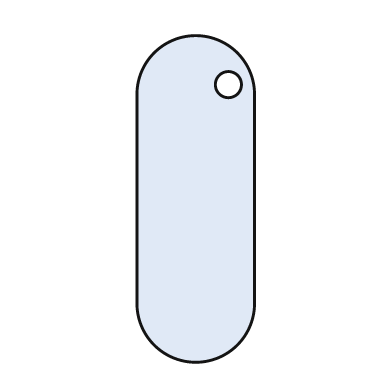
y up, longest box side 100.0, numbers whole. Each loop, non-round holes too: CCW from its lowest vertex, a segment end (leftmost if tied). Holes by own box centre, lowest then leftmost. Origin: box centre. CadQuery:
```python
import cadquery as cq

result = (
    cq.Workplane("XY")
    .moveTo(-18.0, -32.0)
    .threePointArc((0.0, -50.0), (18.0, -32.0))
    .lineTo(18.0, 32.0)
    .threePointArc((0.0, 50.0), (-18.0, 32.0))
    .close()
    .moveTo(10.0, 35.0)
    .circle(4.0)
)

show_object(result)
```